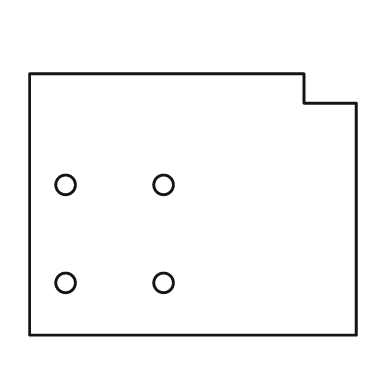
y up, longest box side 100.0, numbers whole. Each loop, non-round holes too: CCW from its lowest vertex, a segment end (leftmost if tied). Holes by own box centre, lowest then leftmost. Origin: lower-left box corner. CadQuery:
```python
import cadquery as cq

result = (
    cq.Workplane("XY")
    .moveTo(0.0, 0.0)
    .lineTo(100.0, 0.0)
    .lineTo(100.0, 71.0)
    .lineTo(84.0, 71.0)
    .lineTo(84.0, 80.0)
    .lineTo(0.0, 80.0)
    .close()
    .moveTo(11.0, 16.0)
    .circle(3.0)
    .moveTo(41.0, 16.0)
    .circle(3.0)
    .moveTo(11.0, 46.0)
    .circle(3.0)
    .moveTo(41.0, 46.0)
    .circle(3.0)
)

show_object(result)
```